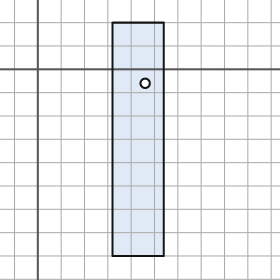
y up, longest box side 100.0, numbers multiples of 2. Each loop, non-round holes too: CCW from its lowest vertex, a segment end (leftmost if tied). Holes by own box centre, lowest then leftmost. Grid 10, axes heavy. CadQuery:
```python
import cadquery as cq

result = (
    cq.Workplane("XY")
    .moveTo(32.0, -80.0)
    .lineTo(54.0, -80.0)
    .lineTo(54.0, 20.0)
    .lineTo(32.0, 20.0)
    .close()
    .moveTo(46.0, -6.0)
    .circle(2.0)
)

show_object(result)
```